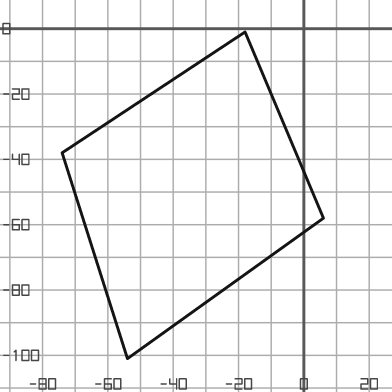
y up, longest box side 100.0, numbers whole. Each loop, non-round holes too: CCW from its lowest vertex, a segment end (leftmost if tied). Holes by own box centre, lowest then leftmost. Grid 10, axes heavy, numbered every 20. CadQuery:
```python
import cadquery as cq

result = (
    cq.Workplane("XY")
    .moveTo(-54.0, -101.0)
    .lineTo(6.0, -58.0)
    .lineTo(-18.0, -1.0)
    .lineTo(-74.0, -38.0)
    .close()
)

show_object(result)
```